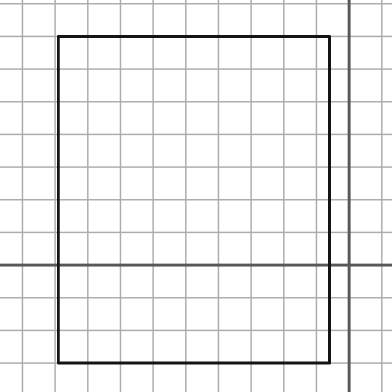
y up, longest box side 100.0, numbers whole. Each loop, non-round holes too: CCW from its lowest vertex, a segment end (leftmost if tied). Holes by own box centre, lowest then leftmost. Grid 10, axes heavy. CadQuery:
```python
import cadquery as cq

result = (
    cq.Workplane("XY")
    .moveTo(-89.0, -30.0)
    .lineTo(-6.0, -30.0)
    .lineTo(-6.0, 70.0)
    .lineTo(-89.0, 70.0)
    .close()
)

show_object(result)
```